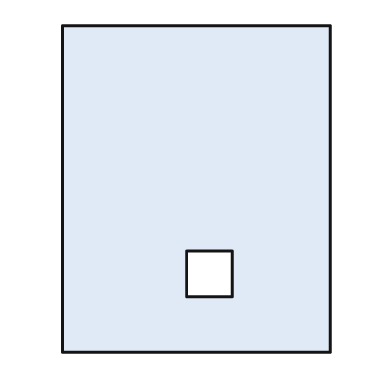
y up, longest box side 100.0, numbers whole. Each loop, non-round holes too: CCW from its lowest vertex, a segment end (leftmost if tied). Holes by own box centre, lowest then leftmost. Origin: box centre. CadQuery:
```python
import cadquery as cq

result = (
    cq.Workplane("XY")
    .moveTo(-41.0, -50.0)
    .lineTo(41.0, -50.0)
    .lineTo(41.0, 50.0)
    .lineTo(-41.0, 50.0)
    .close()
    .moveTo(-3.0, -33.0)
    .lineTo(11.0, -33.0)
    .lineTo(11.0, -19.0)
    .lineTo(-3.0, -19.0)
    .close()
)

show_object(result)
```